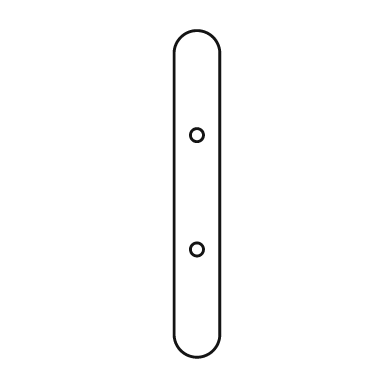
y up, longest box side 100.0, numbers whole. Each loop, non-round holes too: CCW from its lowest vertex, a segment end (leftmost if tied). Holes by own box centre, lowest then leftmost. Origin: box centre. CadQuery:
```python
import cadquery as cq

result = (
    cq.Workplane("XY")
    .moveTo(-7.0, -43.0)
    .threePointArc((0.0, -50.0), (7.0, -43.0))
    .lineTo(7.0, 43.0)
    .threePointArc((0.0, 50.0), (-7.0, 43.0))
    .close()
    .moveTo(0.0, -17.0)
    .circle(2.0)
    .moveTo(0.0, 18.0)
    .circle(2.0)
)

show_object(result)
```